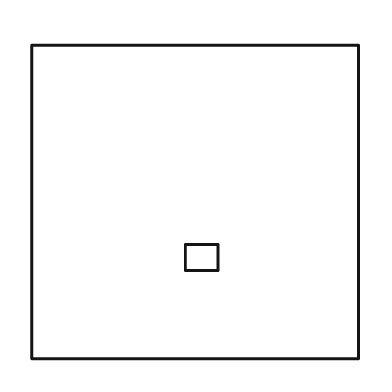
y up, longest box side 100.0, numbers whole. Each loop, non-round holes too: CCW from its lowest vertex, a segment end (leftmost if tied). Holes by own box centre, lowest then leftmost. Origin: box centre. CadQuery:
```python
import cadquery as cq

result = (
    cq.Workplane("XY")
    .moveTo(-50.0, -48.0)
    .lineTo(50.0, -48.0)
    .lineTo(50.0, 48.0)
    .lineTo(-50.0, 48.0)
    .close()
    .moveTo(-3.0, -21.0)
    .lineTo(7.0, -21.0)
    .lineTo(7.0, -13.0)
    .lineTo(-3.0, -13.0)
    .close()
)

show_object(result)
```